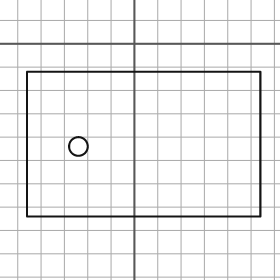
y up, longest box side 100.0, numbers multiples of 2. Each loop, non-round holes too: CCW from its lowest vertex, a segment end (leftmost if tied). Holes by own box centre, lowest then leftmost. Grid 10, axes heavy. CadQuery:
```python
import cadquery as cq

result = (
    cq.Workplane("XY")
    .moveTo(-46.0, -74.0)
    .lineTo(54.0, -74.0)
    .lineTo(54.0, -12.0)
    .lineTo(-46.0, -12.0)
    .close()
    .moveTo(-24.0, -44.0)
    .circle(4.0)
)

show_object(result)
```